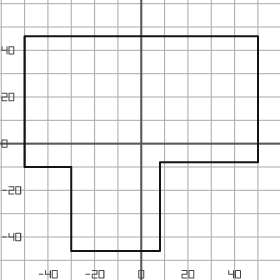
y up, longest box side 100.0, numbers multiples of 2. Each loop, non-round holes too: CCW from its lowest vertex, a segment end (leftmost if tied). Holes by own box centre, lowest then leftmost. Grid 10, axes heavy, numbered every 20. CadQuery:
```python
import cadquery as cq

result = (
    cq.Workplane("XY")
    .moveTo(-30.0, -46.0)
    .lineTo(8.0, -46.0)
    .lineTo(8.0, -8.0)
    .lineTo(50.0, -8.0)
    .lineTo(50.0, 46.0)
    .lineTo(-50.0, 46.0)
    .lineTo(-50.0, -10.0)
    .lineTo(-30.0, -10.0)
    .close()
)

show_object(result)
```